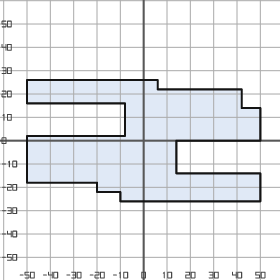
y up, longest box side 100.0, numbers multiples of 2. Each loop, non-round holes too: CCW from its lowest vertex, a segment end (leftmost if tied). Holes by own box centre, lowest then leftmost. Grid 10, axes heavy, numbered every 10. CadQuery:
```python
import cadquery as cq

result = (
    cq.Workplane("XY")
    .moveTo(-10.0, -26.0)
    .lineTo(50.0, -26.0)
    .lineTo(50.0, -14.0)
    .lineTo(14.0, -14.0)
    .lineTo(14.0, 0.0)
    .lineTo(50.0, 0.0)
    .lineTo(50.0, 14.0)
    .lineTo(42.0, 14.0)
    .lineTo(42.0, 22.0)
    .lineTo(6.0, 22.0)
    .lineTo(6.0, 26.0)
    .lineTo(-50.0, 26.0)
    .lineTo(-50.0, 16.0)
    .lineTo(-8.0, 16.0)
    .lineTo(-8.0, 2.0)
    .lineTo(-50.0, 2.0)
    .lineTo(-50.0, -18.0)
    .lineTo(-20.0, -18.0)
    .lineTo(-20.0, -22.0)
    .lineTo(-10.0, -22.0)
    .close()
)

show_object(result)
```